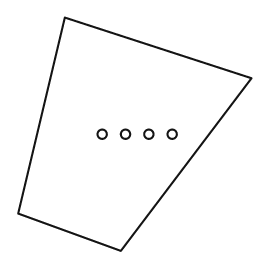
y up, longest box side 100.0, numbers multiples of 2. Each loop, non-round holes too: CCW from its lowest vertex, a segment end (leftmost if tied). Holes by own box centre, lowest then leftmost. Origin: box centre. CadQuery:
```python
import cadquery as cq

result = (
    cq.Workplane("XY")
    .moveTo(-6.0, -50.0)
    .lineTo(50.0, 24.0)
    .lineTo(-30.0, 50.0)
    .lineTo(-50.0, -34.0)
    .close()
    .moveTo(-14.0, 0.0)
    .circle(2.0)
    .moveTo(-4.0, 0.0)
    .circle(2.0)
    .moveTo(6.0, 0.0)
    .circle(2.0)
    .moveTo(16.0, 0.0)
    .circle(2.0)
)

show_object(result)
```